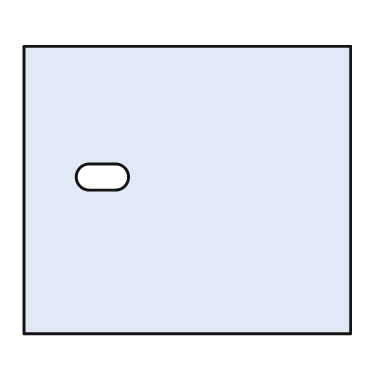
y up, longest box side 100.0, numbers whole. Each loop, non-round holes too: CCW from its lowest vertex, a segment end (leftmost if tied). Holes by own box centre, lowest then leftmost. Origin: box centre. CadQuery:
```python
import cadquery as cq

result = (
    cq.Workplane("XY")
    .moveTo(-50.0, -44.0)
    .lineTo(50.0, -44.0)
    .lineTo(50.0, 44.0)
    .lineTo(-50.0, 44.0)
    .close()
    .moveTo(-30.0, 0.0)
    .lineTo(-22.0, 0.0)
    .threePointArc((-18.0, 4.0), (-22.0, 8.0))
    .lineTo(-30.0, 8.0)
    .threePointArc((-34.0, 4.0), (-30.0, 0.0))
    .close()
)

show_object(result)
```